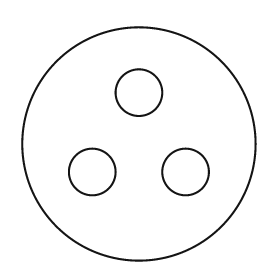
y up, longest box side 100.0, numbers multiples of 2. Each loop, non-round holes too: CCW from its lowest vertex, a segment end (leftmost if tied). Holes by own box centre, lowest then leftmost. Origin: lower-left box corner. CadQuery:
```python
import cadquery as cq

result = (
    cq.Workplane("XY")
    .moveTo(50.0, 50.0)
    .circle(50.0)
    .moveTo(30.0, 38.0)
    .circle(10.0)
    .moveTo(70.0, 38.0)
    .circle(10.0)
    .moveTo(50.0, 72.0)
    .circle(10.0)
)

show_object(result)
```